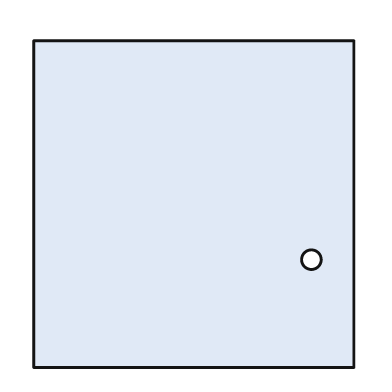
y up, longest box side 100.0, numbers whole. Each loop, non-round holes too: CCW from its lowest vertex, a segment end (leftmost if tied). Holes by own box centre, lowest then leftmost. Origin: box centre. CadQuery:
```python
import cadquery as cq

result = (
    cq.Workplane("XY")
    .moveTo(-49.0, -50.0)
    .lineTo(49.0, -50.0)
    .lineTo(49.0, 50.0)
    .lineTo(-49.0, 50.0)
    .close()
    .moveTo(36.0, -17.0)
    .circle(3.0)
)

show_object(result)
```